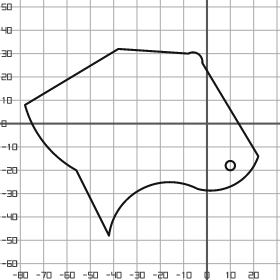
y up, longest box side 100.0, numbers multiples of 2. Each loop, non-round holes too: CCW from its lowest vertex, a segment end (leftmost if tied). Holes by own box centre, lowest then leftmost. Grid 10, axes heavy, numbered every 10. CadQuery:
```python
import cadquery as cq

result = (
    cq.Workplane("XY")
    .moveTo(-42.0, -48.0)
    .threePointArc((-28.0, -28.0), (-4.0, -28.0))
    .threePointArc((12.0, -26.0), (22.0, -14.0))
    .lineTo(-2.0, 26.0)
    .threePointArc((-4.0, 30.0), (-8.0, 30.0))
    .lineTo(-38.0, 32.0)
    .lineTo(-78.0, 8.0)
    .threePointArc((-70.0, -8.0), (-56.0, -20.0))
    .close()
    .moveTo(10.0, -18.0)
    .circle(2.0)
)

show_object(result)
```